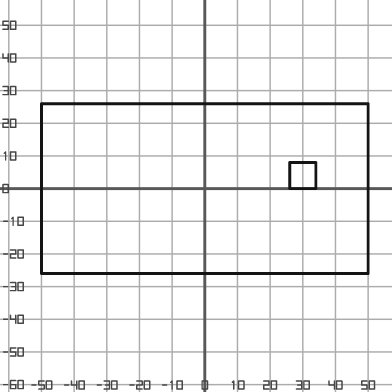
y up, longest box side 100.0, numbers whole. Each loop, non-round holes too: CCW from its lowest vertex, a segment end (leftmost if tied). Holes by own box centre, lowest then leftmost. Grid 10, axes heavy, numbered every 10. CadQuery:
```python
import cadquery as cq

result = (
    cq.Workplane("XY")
    .moveTo(-50.0, -26.0)
    .lineTo(50.0, -26.0)
    .lineTo(50.0, 26.0)
    .lineTo(-50.0, 26.0)
    .close()
    .moveTo(26.0, 0.0)
    .lineTo(34.0, 0.0)
    .lineTo(34.0, 8.0)
    .lineTo(26.0, 8.0)
    .close()
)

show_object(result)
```